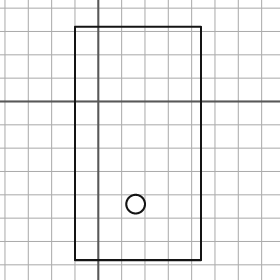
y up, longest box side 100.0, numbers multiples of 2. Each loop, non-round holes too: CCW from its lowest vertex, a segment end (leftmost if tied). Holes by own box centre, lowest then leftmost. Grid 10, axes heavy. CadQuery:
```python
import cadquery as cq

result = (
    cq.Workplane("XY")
    .moveTo(-10.0, -68.0)
    .lineTo(44.0, -68.0)
    .lineTo(44.0, 32.0)
    .lineTo(-10.0, 32.0)
    .close()
    .moveTo(16.0, -44.0)
    .circle(4.0)
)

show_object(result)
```